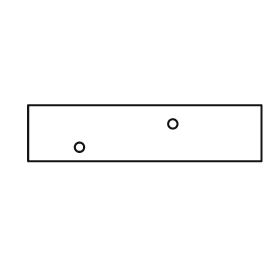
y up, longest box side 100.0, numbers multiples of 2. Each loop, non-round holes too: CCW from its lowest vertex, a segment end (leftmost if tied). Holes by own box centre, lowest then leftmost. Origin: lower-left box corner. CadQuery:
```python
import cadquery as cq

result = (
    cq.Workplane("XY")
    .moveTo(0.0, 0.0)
    .lineTo(100.0, 0.0)
    .lineTo(100.0, 24.0)
    .lineTo(0.0, 24.0)
    .close()
    .moveTo(22.0, 6.0)
    .circle(2.0)
    .moveTo(62.0, 16.0)
    .circle(2.0)
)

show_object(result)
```